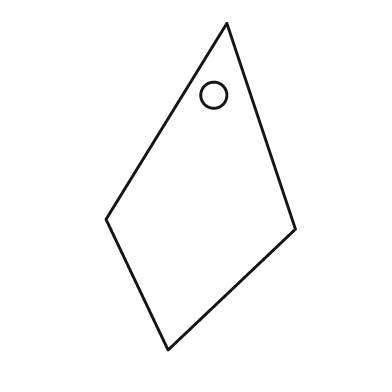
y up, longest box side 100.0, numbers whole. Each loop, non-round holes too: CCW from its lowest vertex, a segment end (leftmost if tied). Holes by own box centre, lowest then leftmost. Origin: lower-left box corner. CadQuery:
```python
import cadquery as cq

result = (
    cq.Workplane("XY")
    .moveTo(19.0, 0.0)
    .lineTo(58.0, 37.0)
    .lineTo(37.0, 100.0)
    .lineTo(0.0, 40.0)
    .close()
    .moveTo(33.0, 78.0)
    .circle(4.0)
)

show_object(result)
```